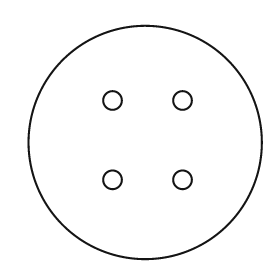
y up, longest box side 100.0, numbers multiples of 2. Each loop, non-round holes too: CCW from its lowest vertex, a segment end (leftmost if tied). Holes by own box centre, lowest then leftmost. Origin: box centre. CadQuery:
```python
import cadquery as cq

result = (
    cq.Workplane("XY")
    .moveTo(0.0, 0.0)
    .circle(50.0)
    .moveTo(-14.0, -16.0)
    .circle(4.0)
    .moveTo(16.0, -16.0)
    .circle(4.0)
    .moveTo(-14.0, 18.0)
    .circle(4.0)
    .moveTo(16.0, 18.0)
    .circle(4.0)
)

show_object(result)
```